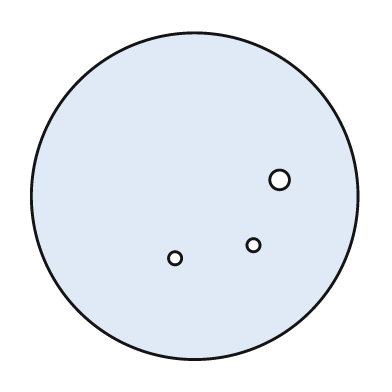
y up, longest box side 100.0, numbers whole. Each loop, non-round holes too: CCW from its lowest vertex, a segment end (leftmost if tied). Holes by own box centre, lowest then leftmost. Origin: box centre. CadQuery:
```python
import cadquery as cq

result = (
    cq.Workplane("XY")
    .moveTo(0.0, 0.0)
    .circle(50.0)
    .moveTo(-6.0, -19.0)
    .circle(2.0)
    .moveTo(18.0, -15.0)
    .circle(2.0)
    .moveTo(26.0, 5.0)
    .circle(3.0)
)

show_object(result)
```